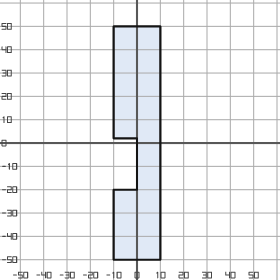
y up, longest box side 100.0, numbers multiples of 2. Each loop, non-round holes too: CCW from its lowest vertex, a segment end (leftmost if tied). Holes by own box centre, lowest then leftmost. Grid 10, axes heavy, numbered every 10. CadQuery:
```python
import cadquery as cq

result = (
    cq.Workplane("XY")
    .moveTo(-10.0, -50.0)
    .lineTo(10.0, -50.0)
    .lineTo(10.0, 50.0)
    .lineTo(-10.0, 50.0)
    .lineTo(-10.0, 2.0)
    .lineTo(0.0, 2.0)
    .lineTo(0.0, -20.0)
    .lineTo(-10.0, -20.0)
    .close()
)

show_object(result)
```